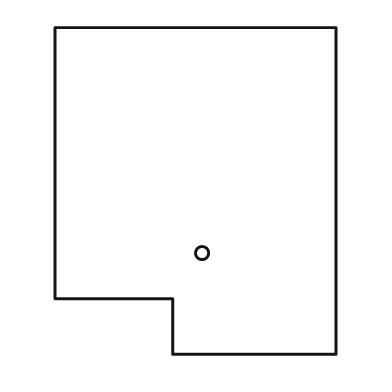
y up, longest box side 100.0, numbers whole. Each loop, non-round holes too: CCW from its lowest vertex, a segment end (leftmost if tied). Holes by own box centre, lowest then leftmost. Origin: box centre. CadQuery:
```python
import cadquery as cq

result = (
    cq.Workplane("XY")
    .moveTo(-7.0, -50.0)
    .lineTo(43.0, -50.0)
    .lineTo(43.0, 50.0)
    .lineTo(-43.0, 50.0)
    .lineTo(-43.0, -33.0)
    .lineTo(-7.0, -33.0)
    .close()
    .moveTo(2.0, -19.0)
    .circle(2.0)
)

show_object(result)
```